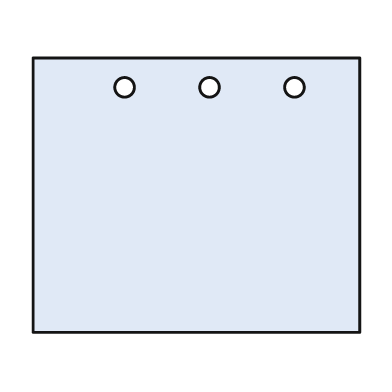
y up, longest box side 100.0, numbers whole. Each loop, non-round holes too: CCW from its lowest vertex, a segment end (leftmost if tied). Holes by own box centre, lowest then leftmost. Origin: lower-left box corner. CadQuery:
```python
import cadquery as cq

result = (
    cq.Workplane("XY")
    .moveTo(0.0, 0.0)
    .lineTo(100.0, 0.0)
    .lineTo(100.0, 84.0)
    .lineTo(0.0, 84.0)
    .close()
    .moveTo(28.0, 75.0)
    .circle(3.0)
    .moveTo(54.0, 75.0)
    .circle(3.0)
    .moveTo(80.0, 75.0)
    .circle(3.0)
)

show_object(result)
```